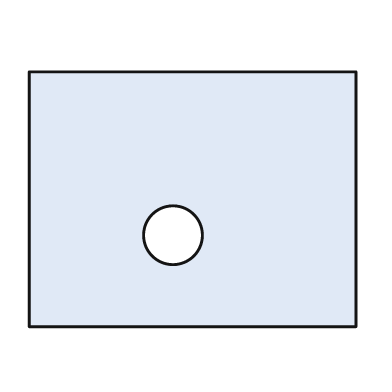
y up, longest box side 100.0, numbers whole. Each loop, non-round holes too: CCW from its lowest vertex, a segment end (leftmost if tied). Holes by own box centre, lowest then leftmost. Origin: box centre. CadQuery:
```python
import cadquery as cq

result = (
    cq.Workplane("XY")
    .moveTo(-50.0, -39.0)
    .lineTo(50.0, -39.0)
    .lineTo(50.0, 39.0)
    .lineTo(-50.0, 39.0)
    .close()
    .moveTo(-6.0, -11.0)
    .circle(9.0)
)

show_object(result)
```